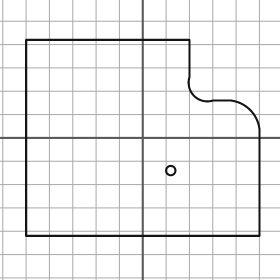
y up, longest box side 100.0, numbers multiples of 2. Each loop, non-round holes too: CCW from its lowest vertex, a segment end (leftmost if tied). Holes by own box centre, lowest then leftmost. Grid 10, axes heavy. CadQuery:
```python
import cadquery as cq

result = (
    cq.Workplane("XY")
    .moveTo(-50.0, -42.0)
    .lineTo(50.0, -42.0)
    .lineTo(50.0, 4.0)
    .threePointArc((46.0, 12.0), (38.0, 16.0))
    .lineTo(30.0, 16.0)
    .threePointArc((22.0, 18.0), (20.0, 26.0))
    .lineTo(20.0, 42.0)
    .lineTo(-50.0, 42.0)
    .close()
    .moveTo(12.0, -14.0)
    .circle(2.0)
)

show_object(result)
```